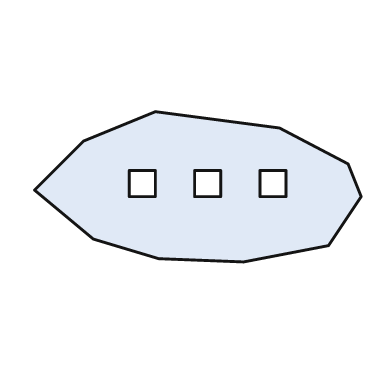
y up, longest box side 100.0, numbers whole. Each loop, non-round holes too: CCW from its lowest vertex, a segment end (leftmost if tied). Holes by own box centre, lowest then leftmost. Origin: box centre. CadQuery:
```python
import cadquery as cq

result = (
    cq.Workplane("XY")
    .moveTo(14.0, -23.0)
    .lineTo(40.0, -18.0)
    .lineTo(50.0, -3.0)
    .lineTo(46.0, 7.0)
    .lineTo(25.0, 18.0)
    .lineTo(-13.0, 23.0)
    .lineTo(-35.0, 14.0)
    .lineTo(-50.0, -1.0)
    .lineTo(-32.0, -16.0)
    .lineTo(-12.0, -22.0)
    .close()
    .moveTo(-21.0, -3.0)
    .lineTo(-13.0, -3.0)
    .lineTo(-13.0, 5.0)
    .lineTo(-21.0, 5.0)
    .close()
    .moveTo(-1.0, -3.0)
    .lineTo(7.0, -3.0)
    .lineTo(7.0, 5.0)
    .lineTo(-1.0, 5.0)
    .close()
    .moveTo(19.0, -3.0)
    .lineTo(27.0, -3.0)
    .lineTo(27.0, 5.0)
    .lineTo(19.0, 5.0)
    .close()
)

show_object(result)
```